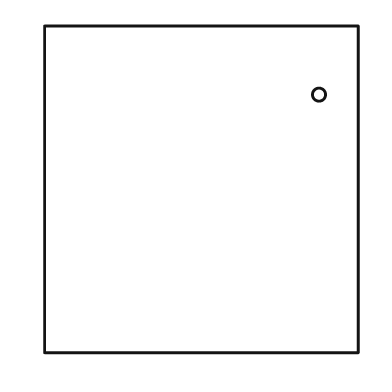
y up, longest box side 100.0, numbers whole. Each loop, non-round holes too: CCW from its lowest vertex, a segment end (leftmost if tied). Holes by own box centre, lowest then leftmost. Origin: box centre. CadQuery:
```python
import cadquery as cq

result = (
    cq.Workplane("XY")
    .moveTo(-48.0, -50.0)
    .lineTo(48.0, -50.0)
    .lineTo(48.0, 50.0)
    .lineTo(-48.0, 50.0)
    .close()
    .moveTo(36.0, 29.0)
    .circle(2.0)
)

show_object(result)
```